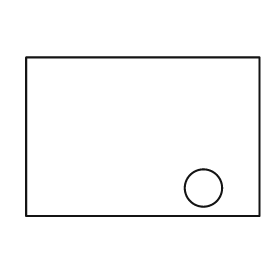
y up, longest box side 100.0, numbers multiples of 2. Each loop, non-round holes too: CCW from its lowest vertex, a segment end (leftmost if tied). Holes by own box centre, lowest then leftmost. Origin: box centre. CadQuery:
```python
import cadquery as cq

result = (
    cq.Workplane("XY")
    .moveTo(-50.0, -34.0)
    .lineTo(50.0, -34.0)
    .lineTo(50.0, 34.0)
    .lineTo(-50.0, 34.0)
    .close()
    .moveTo(26.0, -22.0)
    .circle(8.0)
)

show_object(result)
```